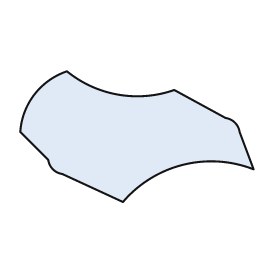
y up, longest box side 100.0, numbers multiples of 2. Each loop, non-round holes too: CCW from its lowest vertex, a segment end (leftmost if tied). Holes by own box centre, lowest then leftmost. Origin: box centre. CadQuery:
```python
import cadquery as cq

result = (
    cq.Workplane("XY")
    .moveTo(-6.0, -28.0)
    .threePointArc((20.0, -12.0), (50.0, -14.0))
    .lineTo(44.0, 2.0)
    .threePointArc((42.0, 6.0), (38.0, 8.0))
    .lineTo(16.0, 20.0)
    .threePointArc((-8.0, 18.0), (-30.0, 28.0))
    .threePointArc((-44.0, 18.0), (-50.0, 2.0))
    .lineTo(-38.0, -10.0)
    .threePointArc((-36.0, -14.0), (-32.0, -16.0))
    .close()
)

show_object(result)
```